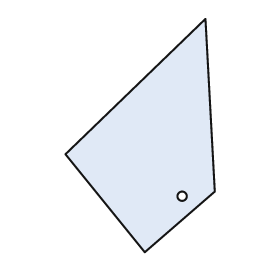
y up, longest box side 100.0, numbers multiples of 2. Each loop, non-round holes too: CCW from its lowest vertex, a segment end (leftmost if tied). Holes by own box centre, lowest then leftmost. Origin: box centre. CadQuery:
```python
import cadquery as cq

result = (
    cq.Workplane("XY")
    .moveTo(2.0, -50.0)
    .lineTo(32.0, -24.0)
    .lineTo(28.0, 50.0)
    .lineTo(-32.0, -8.0)
    .close()
    .moveTo(18.0, -26.0)
    .circle(2.0)
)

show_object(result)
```